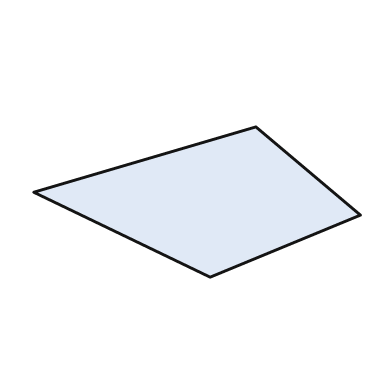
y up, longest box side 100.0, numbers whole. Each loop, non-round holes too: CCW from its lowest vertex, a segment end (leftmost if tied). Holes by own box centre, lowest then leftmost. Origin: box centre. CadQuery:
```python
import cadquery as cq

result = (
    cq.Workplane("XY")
    .moveTo(4.0, -23.0)
    .lineTo(50.0, -4.0)
    .lineTo(18.0, 23.0)
    .lineTo(-50.0, 3.0)
    .close()
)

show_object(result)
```